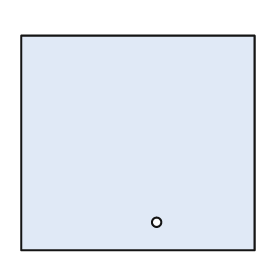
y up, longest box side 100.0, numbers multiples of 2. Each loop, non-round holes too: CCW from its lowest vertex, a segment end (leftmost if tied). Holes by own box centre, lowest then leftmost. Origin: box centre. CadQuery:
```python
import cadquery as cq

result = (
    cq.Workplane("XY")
    .moveTo(-50.0, -46.0)
    .lineTo(50.0, -46.0)
    .lineTo(50.0, 46.0)
    .lineTo(-50.0, 46.0)
    .close()
    .moveTo(8.0, -34.0)
    .circle(2.0)
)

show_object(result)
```